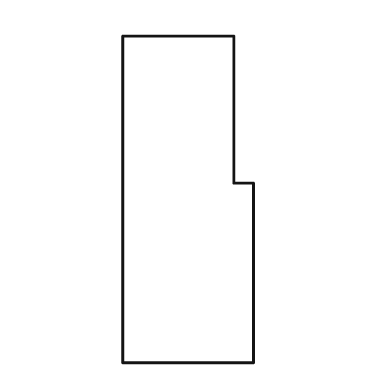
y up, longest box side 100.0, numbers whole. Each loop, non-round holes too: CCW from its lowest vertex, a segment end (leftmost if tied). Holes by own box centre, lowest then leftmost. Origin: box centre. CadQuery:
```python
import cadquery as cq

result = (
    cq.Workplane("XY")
    .moveTo(-20.0, -50.0)
    .lineTo(20.0, -50.0)
    .lineTo(20.0, 5.0)
    .lineTo(14.0, 5.0)
    .lineTo(14.0, 50.0)
    .lineTo(-20.0, 50.0)
    .close()
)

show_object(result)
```